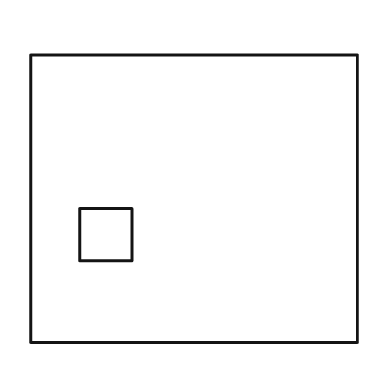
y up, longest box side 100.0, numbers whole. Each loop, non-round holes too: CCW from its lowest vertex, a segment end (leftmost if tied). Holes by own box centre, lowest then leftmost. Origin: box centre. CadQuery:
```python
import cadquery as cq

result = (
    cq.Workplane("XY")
    .moveTo(-50.0, -44.0)
    .lineTo(50.0, -44.0)
    .lineTo(50.0, 44.0)
    .lineTo(-50.0, 44.0)
    .close()
    .moveTo(-35.0, -19.0)
    .lineTo(-19.0, -19.0)
    .lineTo(-19.0, -3.0)
    .lineTo(-35.0, -3.0)
    .close()
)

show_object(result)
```